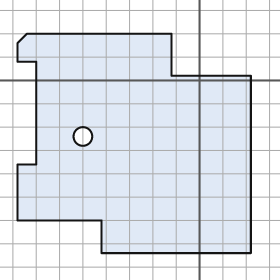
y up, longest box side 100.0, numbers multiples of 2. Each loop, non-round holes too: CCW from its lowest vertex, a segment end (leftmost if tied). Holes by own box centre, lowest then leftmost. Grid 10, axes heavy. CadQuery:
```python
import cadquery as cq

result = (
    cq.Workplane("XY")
    .moveTo(-42.0, -74.0)
    .lineTo(22.0, -74.0)
    .lineTo(22.0, 2.0)
    .lineTo(-12.0, 2.0)
    .lineTo(-12.0, 20.0)
    .lineTo(-74.0, 20.0)
    .lineTo(-78.0, 16.0)
    .lineTo(-78.0, 8.0)
    .lineTo(-70.0, 8.0)
    .lineTo(-70.0, -36.0)
    .lineTo(-78.0, -36.0)
    .lineTo(-78.0, -60.0)
    .lineTo(-42.0, -60.0)
    .close()
    .moveTo(-50.0, -24.0)
    .circle(4.0)
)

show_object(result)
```